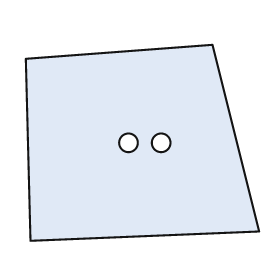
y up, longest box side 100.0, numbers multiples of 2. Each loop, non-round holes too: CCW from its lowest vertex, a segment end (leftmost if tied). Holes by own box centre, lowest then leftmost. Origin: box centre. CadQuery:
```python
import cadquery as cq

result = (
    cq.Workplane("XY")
    .moveTo(-48.0, -42.0)
    .lineTo(50.0, -38.0)
    .lineTo(30.0, 42.0)
    .lineTo(-50.0, 36.0)
    .close()
    .moveTo(-6.0, 0.0)
    .circle(4.0)
    .moveTo(8.0, 0.0)
    .circle(4.0)
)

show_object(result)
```